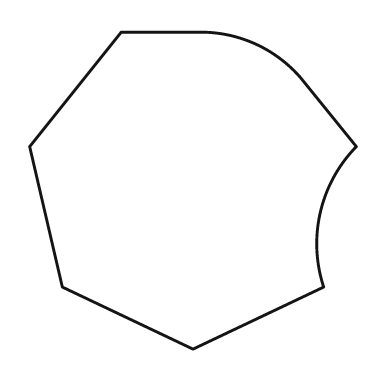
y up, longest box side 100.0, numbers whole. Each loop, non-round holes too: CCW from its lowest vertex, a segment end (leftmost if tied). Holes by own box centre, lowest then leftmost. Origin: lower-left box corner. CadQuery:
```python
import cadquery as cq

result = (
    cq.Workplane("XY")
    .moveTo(50.0, 0.0)
    .lineTo(90.0, 19.0)
    .threePointArc((89.0, 42.0), (100.0, 62.0))
    .lineTo(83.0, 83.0)
    .threePointArc((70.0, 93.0), (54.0, 97.0))
    .lineTo(28.0, 97.0)
    .lineTo(0.0, 62.0)
    .lineTo(10.0, 19.0)
    .close()
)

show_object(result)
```